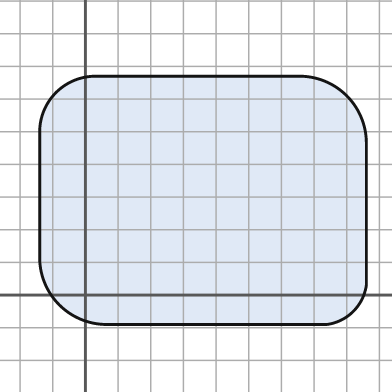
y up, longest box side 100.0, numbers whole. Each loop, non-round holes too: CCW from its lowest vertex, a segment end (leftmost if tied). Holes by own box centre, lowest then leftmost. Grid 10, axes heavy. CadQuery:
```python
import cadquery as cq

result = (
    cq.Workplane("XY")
    .moveTo(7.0, -9.0)
    .lineTo(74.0, -9.0)
    .threePointArc((82.0, -5.0), (86.0, 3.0))
    .lineTo(86.0, 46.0)
    .threePointArc((80.0, 61.0), (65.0, 67.0))
    .lineTo(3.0, 67.0)
    .threePointArc((-9.0, 62.0), (-14.0, 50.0))
    .lineTo(-14.0, 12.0)
    .threePointArc((-8.0, -3.0), (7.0, -9.0))
    .close()
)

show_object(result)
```